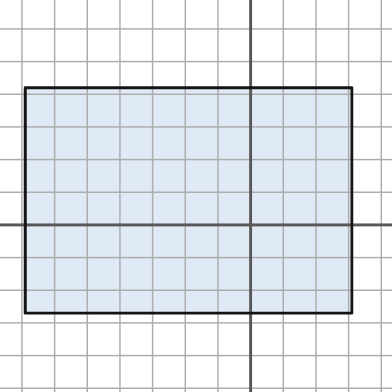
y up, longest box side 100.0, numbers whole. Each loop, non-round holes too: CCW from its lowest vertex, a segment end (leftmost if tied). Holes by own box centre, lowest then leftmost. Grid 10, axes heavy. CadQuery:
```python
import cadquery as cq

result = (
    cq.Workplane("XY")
    .moveTo(-69.0, -27.0)
    .lineTo(31.0, -27.0)
    .lineTo(31.0, 42.0)
    .lineTo(-69.0, 42.0)
    .close()
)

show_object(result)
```